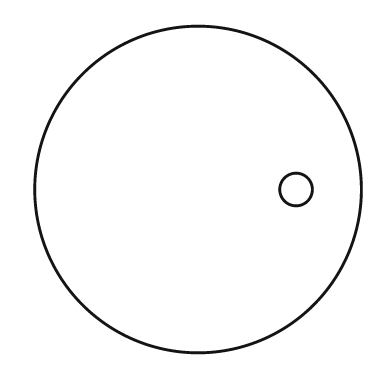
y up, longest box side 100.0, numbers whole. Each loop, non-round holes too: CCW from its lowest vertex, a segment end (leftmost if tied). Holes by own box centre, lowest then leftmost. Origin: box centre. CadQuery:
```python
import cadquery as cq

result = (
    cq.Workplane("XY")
    .moveTo(0.0, 0.0)
    .circle(50.0)
    .moveTo(30.0, 0.0)
    .circle(5.0)
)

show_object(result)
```